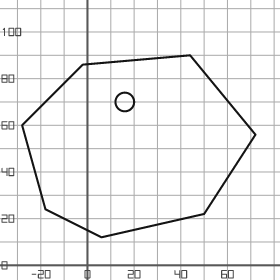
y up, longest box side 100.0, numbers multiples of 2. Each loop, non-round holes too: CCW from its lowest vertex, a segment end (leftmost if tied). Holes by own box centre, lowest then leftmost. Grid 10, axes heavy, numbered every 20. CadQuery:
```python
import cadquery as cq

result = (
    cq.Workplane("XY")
    .moveTo(6.0, 12.0)
    .lineTo(50.0, 22.0)
    .lineTo(72.0, 56.0)
    .lineTo(44.0, 90.0)
    .lineTo(-2.0, 86.0)
    .lineTo(-28.0, 60.0)
    .lineTo(-18.0, 24.0)
    .close()
    .moveTo(16.0, 70.0)
    .circle(4.0)
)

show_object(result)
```